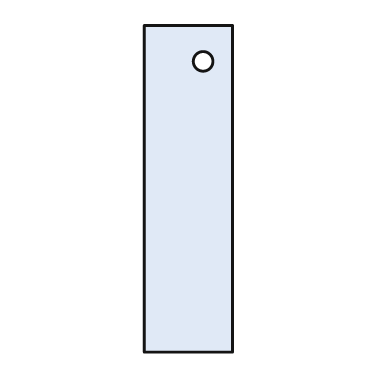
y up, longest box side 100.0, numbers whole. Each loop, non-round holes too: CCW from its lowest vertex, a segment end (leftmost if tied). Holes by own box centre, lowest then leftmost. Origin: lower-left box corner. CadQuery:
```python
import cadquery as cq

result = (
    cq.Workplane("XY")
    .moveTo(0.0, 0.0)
    .lineTo(27.0, 0.0)
    .lineTo(27.0, 100.0)
    .lineTo(0.0, 100.0)
    .close()
    .moveTo(18.0, 89.0)
    .circle(3.0)
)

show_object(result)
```